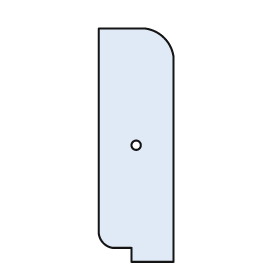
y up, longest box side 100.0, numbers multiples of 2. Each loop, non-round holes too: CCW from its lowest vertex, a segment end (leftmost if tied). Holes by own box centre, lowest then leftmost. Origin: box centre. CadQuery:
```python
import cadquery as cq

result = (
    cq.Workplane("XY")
    .moveTo(-2.0, -50.0)
    .lineTo(16.0, -50.0)
    .lineTo(16.0, 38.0)
    .threePointArc((12.0, 46.0), (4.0, 50.0))
    .lineTo(-16.0, 50.0)
    .lineTo(-16.0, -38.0)
    .threePointArc((-14.0, -42.0), (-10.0, -44.0))
    .lineTo(-2.0, -44.0)
    .close()
    .moveTo(0.0, 0.0)
    .circle(2.0)
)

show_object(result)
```